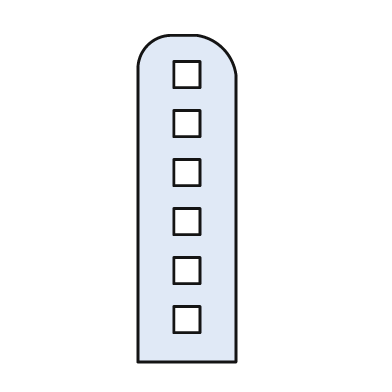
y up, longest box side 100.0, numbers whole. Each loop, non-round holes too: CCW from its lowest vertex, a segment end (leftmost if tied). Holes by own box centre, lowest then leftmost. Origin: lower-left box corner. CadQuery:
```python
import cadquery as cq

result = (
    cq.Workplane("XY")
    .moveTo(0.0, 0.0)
    .lineTo(30.0, 0.0)
    .lineTo(30.0, 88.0)
    .threePointArc((26.0, 96.0), (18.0, 100.0))
    .lineTo(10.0, 100.0)
    .threePointArc((3.0, 97.0), (0.0, 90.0))
    .close()
    .moveTo(11.0, 9.0)
    .lineTo(19.0, 9.0)
    .lineTo(19.0, 17.0)
    .lineTo(11.0, 17.0)
    .close()
    .moveTo(11.0, 24.0)
    .lineTo(19.0, 24.0)
    .lineTo(19.0, 32.0)
    .lineTo(11.0, 32.0)
    .close()
    .moveTo(11.0, 39.0)
    .lineTo(19.0, 39.0)
    .lineTo(19.0, 47.0)
    .lineTo(11.0, 47.0)
    .close()
    .moveTo(11.0, 54.0)
    .lineTo(19.0, 54.0)
    .lineTo(19.0, 62.0)
    .lineTo(11.0, 62.0)
    .close()
    .moveTo(11.0, 69.0)
    .lineTo(19.0, 69.0)
    .lineTo(19.0, 77.0)
    .lineTo(11.0, 77.0)
    .close()
    .moveTo(11.0, 84.0)
    .lineTo(19.0, 84.0)
    .lineTo(19.0, 92.0)
    .lineTo(11.0, 92.0)
    .close()
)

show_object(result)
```